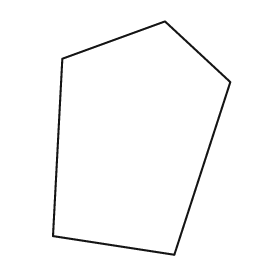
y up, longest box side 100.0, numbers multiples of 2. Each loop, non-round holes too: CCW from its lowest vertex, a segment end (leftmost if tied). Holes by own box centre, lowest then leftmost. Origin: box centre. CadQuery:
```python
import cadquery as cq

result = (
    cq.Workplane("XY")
    .moveTo(14.0, -50.0)
    .lineTo(38.0, 24.0)
    .lineTo(10.0, 50.0)
    .lineTo(-34.0, 34.0)
    .lineTo(-38.0, -42.0)
    .close()
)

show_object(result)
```